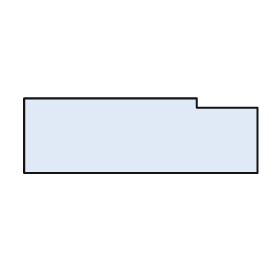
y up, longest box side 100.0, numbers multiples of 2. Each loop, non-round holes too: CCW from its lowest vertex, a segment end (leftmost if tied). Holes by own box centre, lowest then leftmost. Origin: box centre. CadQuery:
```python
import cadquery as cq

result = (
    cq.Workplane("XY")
    .moveTo(-50.0, -16.0)
    .lineTo(50.0, -16.0)
    .lineTo(50.0, 12.0)
    .lineTo(24.0, 12.0)
    .lineTo(24.0, 16.0)
    .lineTo(-50.0, 16.0)
    .close()
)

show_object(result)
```